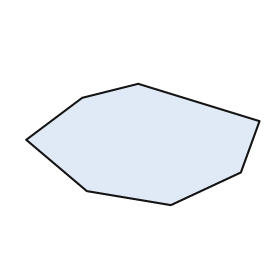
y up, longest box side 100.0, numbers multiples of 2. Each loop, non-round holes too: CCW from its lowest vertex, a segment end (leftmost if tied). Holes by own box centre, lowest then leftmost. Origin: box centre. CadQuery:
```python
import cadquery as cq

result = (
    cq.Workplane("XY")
    .moveTo(12.0, -26.0)
    .lineTo(42.0, -12.0)
    .lineTo(50.0, 10.0)
    .lineTo(-2.0, 26.0)
    .lineTo(-26.0, 20.0)
    .lineTo(-50.0, 2.0)
    .lineTo(-24.0, -20.0)
    .close()
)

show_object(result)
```